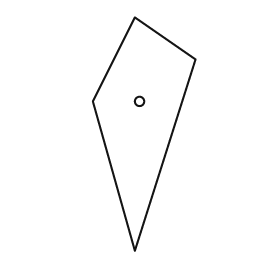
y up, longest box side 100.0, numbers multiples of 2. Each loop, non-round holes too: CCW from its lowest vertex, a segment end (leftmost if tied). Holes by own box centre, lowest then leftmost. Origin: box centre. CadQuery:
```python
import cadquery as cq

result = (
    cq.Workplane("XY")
    .moveTo(-4.0, -50.0)
    .lineTo(22.0, 32.0)
    .lineTo(-4.0, 50.0)
    .lineTo(-22.0, 14.0)
    .close()
    .moveTo(-2.0, 14.0)
    .circle(2.0)
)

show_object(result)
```